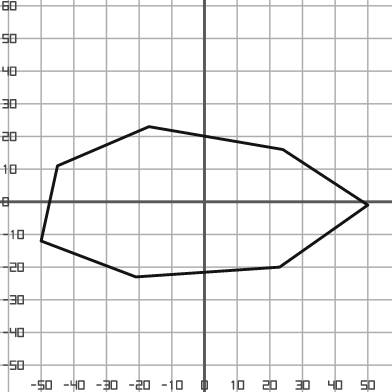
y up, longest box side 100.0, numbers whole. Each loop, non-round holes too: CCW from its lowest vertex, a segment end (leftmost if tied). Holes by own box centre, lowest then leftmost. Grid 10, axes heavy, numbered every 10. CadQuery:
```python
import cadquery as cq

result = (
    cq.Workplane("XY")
    .moveTo(-21.0, -23.0)
    .lineTo(23.0, -20.0)
    .lineTo(50.0, -1.0)
    .lineTo(24.0, 16.0)
    .lineTo(-17.0, 23.0)
    .lineTo(-45.0, 11.0)
    .lineTo(-50.0, -12.0)
    .close()
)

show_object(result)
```